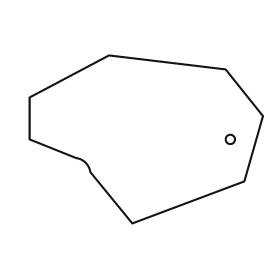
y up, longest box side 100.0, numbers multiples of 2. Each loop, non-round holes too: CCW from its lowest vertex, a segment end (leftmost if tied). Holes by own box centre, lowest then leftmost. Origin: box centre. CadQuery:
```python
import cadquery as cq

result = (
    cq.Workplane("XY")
    .moveTo(-6.0, -36.0)
    .lineTo(42.0, -18.0)
    .lineTo(50.0, 10.0)
    .lineTo(34.0, 30.0)
    .lineTo(-16.0, 36.0)
    .lineTo(-50.0, 18.0)
    .lineTo(-50.0, 0.0)
    .lineTo(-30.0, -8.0)
    .threePointArc((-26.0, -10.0), (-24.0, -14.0))
    .close()
    .moveTo(36.0, 0.0)
    .circle(2.0)
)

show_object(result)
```